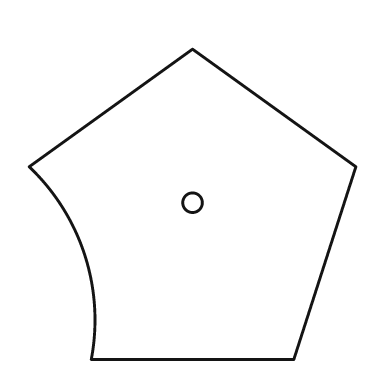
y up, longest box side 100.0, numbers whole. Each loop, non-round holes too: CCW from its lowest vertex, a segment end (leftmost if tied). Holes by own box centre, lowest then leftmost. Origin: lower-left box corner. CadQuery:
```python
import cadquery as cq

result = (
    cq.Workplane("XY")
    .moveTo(19.0, 0.0)
    .lineTo(81.0, 0.0)
    .lineTo(100.0, 59.0)
    .lineTo(50.0, 95.0)
    .lineTo(0.0, 59.0)
    .threePointArc((17.0, 32.0), (19.0, 0.0))
    .close()
    .moveTo(50.0, 48.0)
    .circle(3.0)
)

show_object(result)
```